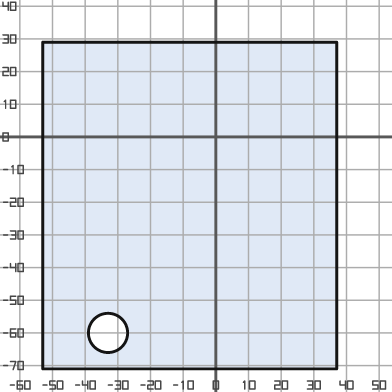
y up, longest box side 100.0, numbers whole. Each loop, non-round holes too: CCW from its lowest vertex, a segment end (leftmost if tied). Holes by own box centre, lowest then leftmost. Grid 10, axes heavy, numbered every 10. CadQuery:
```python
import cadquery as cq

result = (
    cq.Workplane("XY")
    .moveTo(-53.0, -71.0)
    .lineTo(37.0, -71.0)
    .lineTo(37.0, 29.0)
    .lineTo(-53.0, 29.0)
    .close()
    .moveTo(-33.0, -60.0)
    .circle(6.0)
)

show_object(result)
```